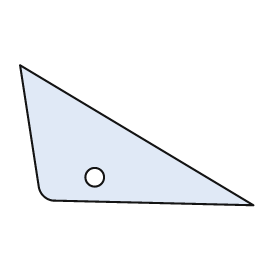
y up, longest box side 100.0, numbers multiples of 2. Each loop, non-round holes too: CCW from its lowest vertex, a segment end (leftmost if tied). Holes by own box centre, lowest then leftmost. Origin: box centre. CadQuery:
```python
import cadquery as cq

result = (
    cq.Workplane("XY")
    .moveTo(50.0, -30.0)
    .lineTo(-50.0, 30.0)
    .lineTo(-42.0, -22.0)
    .threePointArc((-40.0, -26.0), (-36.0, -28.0))
    .close()
    .moveTo(-18.0, -18.0)
    .circle(4.0)
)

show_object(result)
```